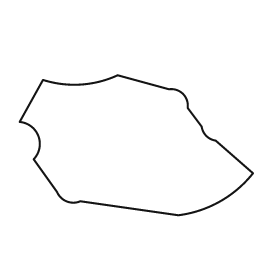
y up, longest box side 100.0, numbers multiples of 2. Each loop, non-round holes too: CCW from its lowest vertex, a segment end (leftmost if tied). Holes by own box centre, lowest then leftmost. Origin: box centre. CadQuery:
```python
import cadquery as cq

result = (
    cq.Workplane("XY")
    .moveTo(18.0, -30.0)
    .threePointArc((36.0, -24.0), (50.0, -12.0))
    .lineTo(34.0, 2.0)
    .threePointArc((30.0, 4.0), (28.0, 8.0))
    .lineTo(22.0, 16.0)
    .threePointArc((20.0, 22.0), (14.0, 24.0))
    .lineTo(-8.0, 30.0)
    .threePointArc((-24.0, 26.0), (-40.0, 28.0))
    .lineTo(-50.0, 10.0)
    .threePointArc((-42.0, 4.0), (-44.0, -6.0))
    .lineTo(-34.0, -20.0)
    .threePointArc((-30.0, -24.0), (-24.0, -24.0))
    .close()
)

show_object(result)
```